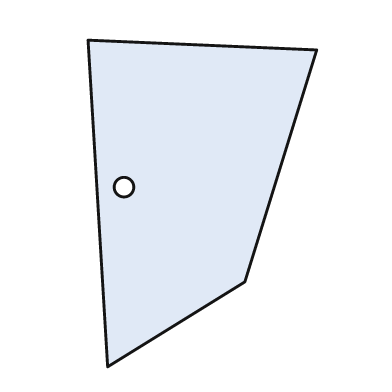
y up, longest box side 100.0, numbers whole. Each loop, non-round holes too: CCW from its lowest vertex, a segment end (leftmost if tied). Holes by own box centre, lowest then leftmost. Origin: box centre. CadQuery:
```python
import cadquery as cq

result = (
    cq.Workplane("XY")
    .moveTo(-29.0, -50.0)
    .lineTo(13.0, -24.0)
    .lineTo(35.0, 47.0)
    .lineTo(-35.0, 50.0)
    .close()
    .moveTo(-24.0, 5.0)
    .circle(3.0)
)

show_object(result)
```